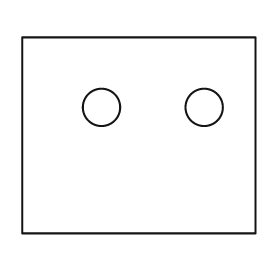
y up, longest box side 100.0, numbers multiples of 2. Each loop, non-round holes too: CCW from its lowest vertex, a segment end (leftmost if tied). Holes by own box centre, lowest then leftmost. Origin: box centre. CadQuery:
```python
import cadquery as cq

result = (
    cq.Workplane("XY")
    .moveTo(-50.0, -42.0)
    .lineTo(50.0, -42.0)
    .lineTo(50.0, 42.0)
    .lineTo(-50.0, 42.0)
    .close()
    .moveTo(-16.0, 12.0)
    .circle(8.0)
    .moveTo(28.0, 12.0)
    .circle(8.0)
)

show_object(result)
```